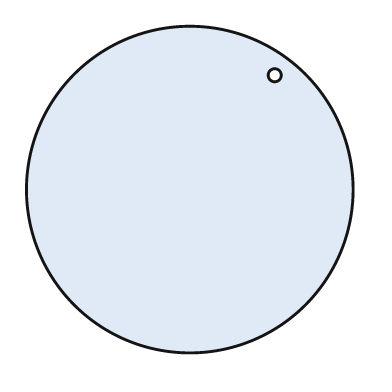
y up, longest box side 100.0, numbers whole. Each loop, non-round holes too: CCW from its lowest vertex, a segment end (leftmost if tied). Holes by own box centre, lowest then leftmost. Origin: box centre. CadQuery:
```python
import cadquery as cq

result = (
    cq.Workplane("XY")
    .moveTo(0.0, 0.0)
    .circle(50.0)
    .moveTo(26.0, 35.0)
    .circle(2.0)
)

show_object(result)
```